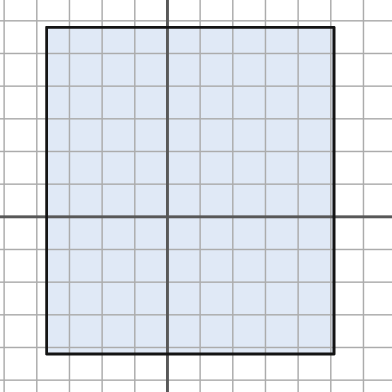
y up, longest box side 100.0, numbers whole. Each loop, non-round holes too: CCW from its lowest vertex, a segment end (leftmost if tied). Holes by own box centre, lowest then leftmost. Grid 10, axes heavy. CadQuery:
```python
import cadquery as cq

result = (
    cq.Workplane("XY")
    .moveTo(-37.0, -42.0)
    .lineTo(51.0, -42.0)
    .lineTo(51.0, 58.0)
    .lineTo(-37.0, 58.0)
    .close()
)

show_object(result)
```